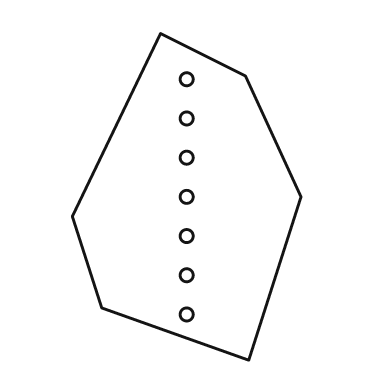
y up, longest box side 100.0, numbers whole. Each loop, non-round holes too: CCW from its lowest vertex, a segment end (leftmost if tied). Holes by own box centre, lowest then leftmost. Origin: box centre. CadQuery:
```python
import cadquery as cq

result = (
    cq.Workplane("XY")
    .moveTo(19.0, -50.0)
    .lineTo(35.0, 0.0)
    .lineTo(18.0, 37.0)
    .lineTo(-8.0, 50.0)
    .lineTo(-35.0, -6.0)
    .lineTo(-26.0, -34.0)
    .close()
    .moveTo(0.0, -36.0)
    .circle(2.0)
    .moveTo(0.0, -24.0)
    .circle(2.0)
    .moveTo(0.0, -12.0)
    .circle(2.0)
    .moveTo(0.0, 0.0)
    .circle(2.0)
    .moveTo(0.0, 12.0)
    .circle(2.0)
    .moveTo(0.0, 24.0)
    .circle(2.0)
    .moveTo(0.0, 36.0)
    .circle(2.0)
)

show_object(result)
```